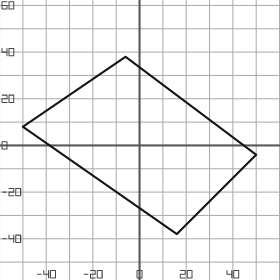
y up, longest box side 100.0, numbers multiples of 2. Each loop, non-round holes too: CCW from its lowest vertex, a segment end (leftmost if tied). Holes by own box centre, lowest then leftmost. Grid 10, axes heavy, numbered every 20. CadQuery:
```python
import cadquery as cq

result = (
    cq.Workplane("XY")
    .moveTo(16.0, -38.0)
    .lineTo(50.0, -4.0)
    .lineTo(-6.0, 38.0)
    .lineTo(-50.0, 8.0)
    .close()
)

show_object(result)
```